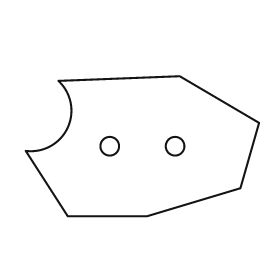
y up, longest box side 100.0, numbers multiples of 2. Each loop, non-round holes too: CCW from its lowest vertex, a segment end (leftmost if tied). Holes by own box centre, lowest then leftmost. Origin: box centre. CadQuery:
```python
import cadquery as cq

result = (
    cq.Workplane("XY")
    .moveTo(-32.0, -30.0)
    .lineTo(2.0, -30.0)
    .lineTo(42.0, -18.0)
    .lineTo(50.0, 10.0)
    .lineTo(16.0, 30.0)
    .lineTo(-36.0, 28.0)
    .threePointArc((-32.0, 8.0), (-50.0, -2.0))
    .close()
    .moveTo(-14.0, 0.0)
    .circle(4.0)
    .moveTo(14.0, 0.0)
    .circle(4.0)
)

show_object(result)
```